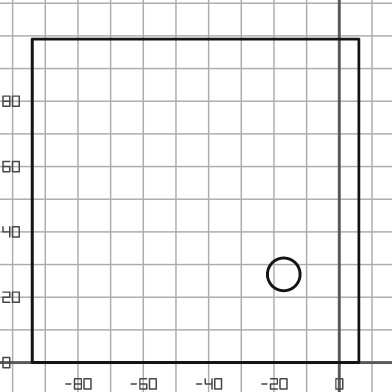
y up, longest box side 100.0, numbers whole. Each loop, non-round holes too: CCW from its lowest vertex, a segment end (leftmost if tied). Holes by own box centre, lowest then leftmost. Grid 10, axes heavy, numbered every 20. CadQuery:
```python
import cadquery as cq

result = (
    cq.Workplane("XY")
    .moveTo(-94.0, 0.0)
    .lineTo(6.0, 0.0)
    .lineTo(6.0, 99.0)
    .lineTo(-94.0, 99.0)
    .close()
    .moveTo(-17.0, 27.0)
    .circle(5.0)
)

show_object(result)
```